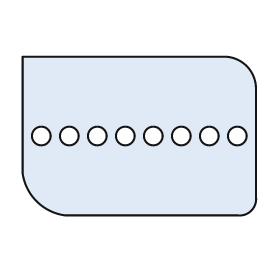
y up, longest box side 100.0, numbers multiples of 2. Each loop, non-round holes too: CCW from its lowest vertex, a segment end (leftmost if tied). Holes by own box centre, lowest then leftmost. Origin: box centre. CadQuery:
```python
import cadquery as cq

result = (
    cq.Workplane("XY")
    .moveTo(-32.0, -34.0)
    .lineTo(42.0, -34.0)
    .threePointArc((48.0, -32.0), (50.0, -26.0))
    .lineTo(50.0, 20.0)
    .threePointArc((46.0, 30.0), (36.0, 34.0))
    .lineTo(-50.0, 34.0)
    .lineTo(-50.0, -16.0)
    .threePointArc((-44.0, -28.0), (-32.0, -34.0))
    .close()
    .moveTo(-42.0, 0.0)
    .circle(4.0)
    .moveTo(-30.0, 0.0)
    .circle(4.0)
    .moveTo(-18.0, 0.0)
    .circle(4.0)
    .moveTo(-6.0, 0.0)
    .circle(4.0)
    .moveTo(6.0, 0.0)
    .circle(4.0)
    .moveTo(18.0, 0.0)
    .circle(4.0)
    .moveTo(30.0, 0.0)
    .circle(4.0)
    .moveTo(42.0, 0.0)
    .circle(4.0)
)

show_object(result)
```